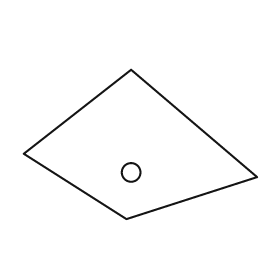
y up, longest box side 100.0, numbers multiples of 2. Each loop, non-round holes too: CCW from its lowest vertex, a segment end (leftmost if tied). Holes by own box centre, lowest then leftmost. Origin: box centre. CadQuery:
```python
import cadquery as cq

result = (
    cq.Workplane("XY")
    .moveTo(-6.0, -32.0)
    .lineTo(50.0, -14.0)
    .lineTo(-4.0, 32.0)
    .lineTo(-50.0, -4.0)
    .close()
    .moveTo(-4.0, -12.0)
    .circle(4.0)
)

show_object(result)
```